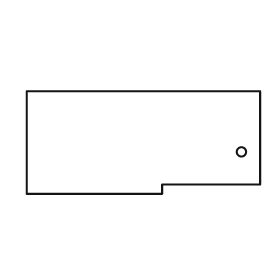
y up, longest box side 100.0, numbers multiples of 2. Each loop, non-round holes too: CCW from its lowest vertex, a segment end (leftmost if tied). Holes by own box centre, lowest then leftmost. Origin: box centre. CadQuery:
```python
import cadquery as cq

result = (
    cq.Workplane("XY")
    .moveTo(-50.0, -22.0)
    .lineTo(8.0, -22.0)
    .lineTo(8.0, -18.0)
    .lineTo(50.0, -18.0)
    .lineTo(50.0, 22.0)
    .lineTo(-50.0, 22.0)
    .close()
    .moveTo(42.0, -4.0)
    .circle(2.0)
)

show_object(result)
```